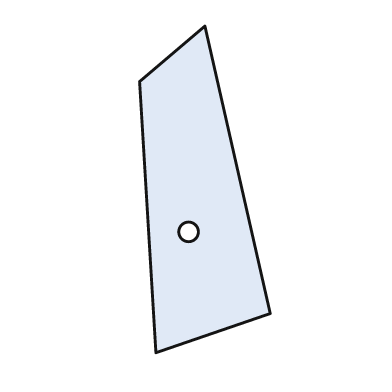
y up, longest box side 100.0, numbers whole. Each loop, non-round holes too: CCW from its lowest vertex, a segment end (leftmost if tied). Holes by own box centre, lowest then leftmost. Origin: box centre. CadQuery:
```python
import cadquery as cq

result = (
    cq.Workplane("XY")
    .moveTo(-15.0, -50.0)
    .lineTo(20.0, -38.0)
    .lineTo(0.0, 50.0)
    .lineTo(-20.0, 33.0)
    .close()
    .moveTo(-5.0, -13.0)
    .circle(3.0)
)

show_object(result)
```